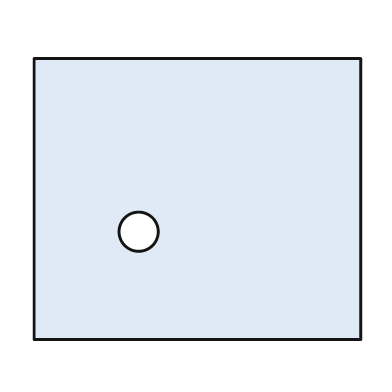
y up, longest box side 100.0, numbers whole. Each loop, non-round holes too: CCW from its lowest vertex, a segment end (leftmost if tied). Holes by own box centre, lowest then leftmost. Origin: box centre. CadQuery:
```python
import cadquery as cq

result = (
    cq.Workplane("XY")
    .moveTo(-50.0, -43.0)
    .lineTo(50.0, -43.0)
    .lineTo(50.0, 43.0)
    .lineTo(-50.0, 43.0)
    .close()
    .moveTo(-18.0, -10.0)
    .circle(6.0)
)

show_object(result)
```